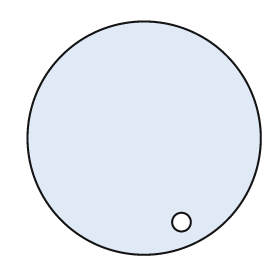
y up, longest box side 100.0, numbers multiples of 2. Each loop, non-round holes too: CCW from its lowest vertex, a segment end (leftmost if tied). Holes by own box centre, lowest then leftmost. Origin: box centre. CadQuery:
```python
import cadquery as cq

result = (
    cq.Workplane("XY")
    .moveTo(0.0, 0.0)
    .circle(50.0)
    .moveTo(16.0, -36.0)
    .circle(4.0)
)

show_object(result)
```